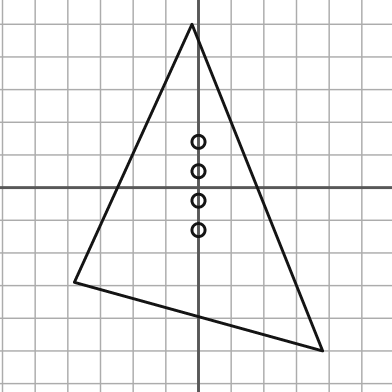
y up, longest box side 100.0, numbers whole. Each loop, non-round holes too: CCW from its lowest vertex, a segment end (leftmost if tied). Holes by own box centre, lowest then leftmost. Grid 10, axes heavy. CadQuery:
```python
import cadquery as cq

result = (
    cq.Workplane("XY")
    .moveTo(38.0, -50.0)
    .lineTo(-2.0, 50.0)
    .lineTo(-38.0, -29.0)
    .close()
    .moveTo(0.0, -13.0)
    .circle(2.0)
    .moveTo(0.0, -4.0)
    .circle(2.0)
    .moveTo(0.0, 5.0)
    .circle(2.0)
    .moveTo(0.0, 14.0)
    .circle(2.0)
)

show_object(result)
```